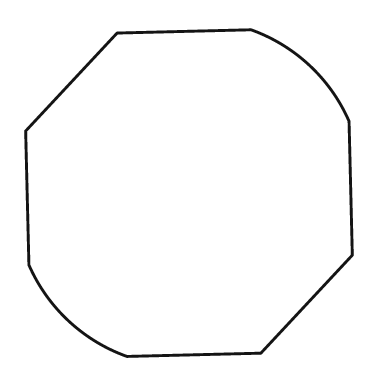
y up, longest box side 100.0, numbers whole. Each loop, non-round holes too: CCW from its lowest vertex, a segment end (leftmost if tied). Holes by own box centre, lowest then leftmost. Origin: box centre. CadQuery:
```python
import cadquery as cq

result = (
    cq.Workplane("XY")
    .moveTo(-19.0, -50.0)
    .lineTo(22.0, -49.0)
    .lineTo(50.0, -19.0)
    .lineTo(49.0, 22.0)
    .threePointArc((37.0, 39.0), (19.0, 50.0))
    .lineTo(-22.0, 49.0)
    .lineTo(-50.0, 19.0)
    .lineTo(-49.0, -22.0)
    .threePointArc((-37.0, -39.0), (-19.0, -50.0))
    .close()
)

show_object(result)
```